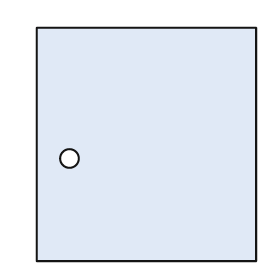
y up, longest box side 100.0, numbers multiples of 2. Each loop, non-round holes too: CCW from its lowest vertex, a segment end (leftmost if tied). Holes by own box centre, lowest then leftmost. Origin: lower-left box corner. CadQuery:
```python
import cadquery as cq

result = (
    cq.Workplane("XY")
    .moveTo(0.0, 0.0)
    .lineTo(94.0, 0.0)
    .lineTo(94.0, 100.0)
    .lineTo(0.0, 100.0)
    .close()
    .moveTo(14.0, 44.0)
    .circle(4.0)
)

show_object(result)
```